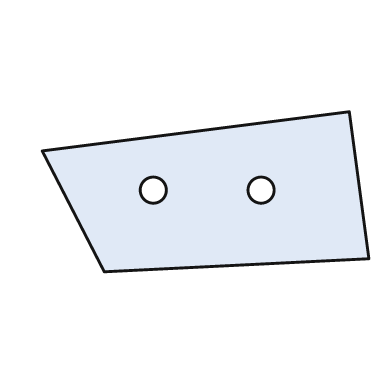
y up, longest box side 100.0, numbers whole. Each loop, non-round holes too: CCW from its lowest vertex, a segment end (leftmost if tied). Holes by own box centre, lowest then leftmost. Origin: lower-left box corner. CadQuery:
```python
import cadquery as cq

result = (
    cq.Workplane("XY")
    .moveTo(19.0, 0.0)
    .lineTo(100.0, 4.0)
    .lineTo(94.0, 49.0)
    .lineTo(0.0, 37.0)
    .close()
    .moveTo(34.0, 25.0)
    .circle(4.0)
    .moveTo(67.0, 25.0)
    .circle(4.0)
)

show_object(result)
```